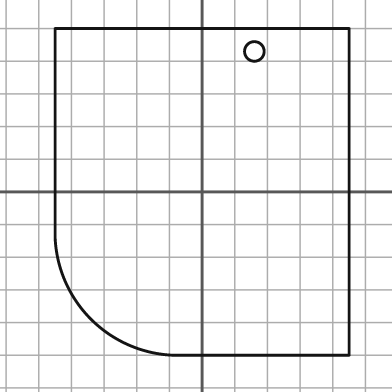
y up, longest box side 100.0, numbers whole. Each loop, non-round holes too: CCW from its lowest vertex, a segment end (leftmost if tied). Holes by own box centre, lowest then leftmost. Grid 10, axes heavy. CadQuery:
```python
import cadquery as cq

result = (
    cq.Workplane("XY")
    .moveTo(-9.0, -50.0)
    .lineTo(45.0, -50.0)
    .lineTo(45.0, 50.0)
    .lineTo(-45.0, 50.0)
    .lineTo(-45.0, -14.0)
    .threePointArc((-34.0, -39.0), (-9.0, -50.0))
    .close()
    .moveTo(16.0, 43.0)
    .circle(3.0)
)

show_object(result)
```